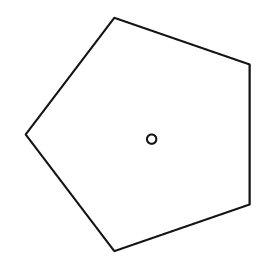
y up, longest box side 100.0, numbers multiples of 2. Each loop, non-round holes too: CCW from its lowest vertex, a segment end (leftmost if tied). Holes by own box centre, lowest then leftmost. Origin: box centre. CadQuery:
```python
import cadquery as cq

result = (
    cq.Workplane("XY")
    .moveTo(-10.0, -50.0)
    .lineTo(48.0, -30.0)
    .lineTo(48.0, 30.0)
    .lineTo(-10.0, 50.0)
    .lineTo(-48.0, 0.0)
    .close()
    .moveTo(6.0, -2.0)
    .circle(2.0)
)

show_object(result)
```